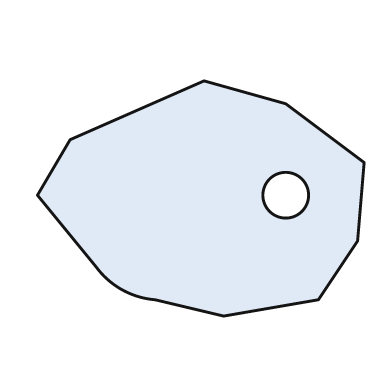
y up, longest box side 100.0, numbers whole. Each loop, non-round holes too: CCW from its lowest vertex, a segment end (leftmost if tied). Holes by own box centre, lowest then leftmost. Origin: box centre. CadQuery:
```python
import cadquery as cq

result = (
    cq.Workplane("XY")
    .moveTo(7.0, -36.0)
    .lineTo(36.0, -31.0)
    .lineTo(48.0, -13.0)
    .lineTo(50.0, 11.0)
    .lineTo(26.0, 29.0)
    .lineTo(1.0, 36.0)
    .lineTo(-40.0, 18.0)
    .lineTo(-50.0, 1.0)
    .lineTo(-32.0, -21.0)
    .threePointArc((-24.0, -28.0), (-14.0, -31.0))
    .close()
    .moveTo(26.0, 1.0)
    .circle(7.0)
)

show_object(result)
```